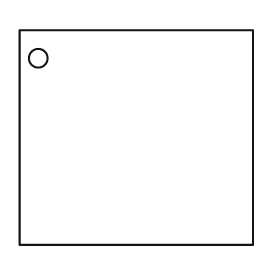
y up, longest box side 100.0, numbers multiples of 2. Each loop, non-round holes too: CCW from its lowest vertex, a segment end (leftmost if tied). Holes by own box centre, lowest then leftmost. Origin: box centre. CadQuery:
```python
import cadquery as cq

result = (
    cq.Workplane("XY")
    .moveTo(-50.0, -46.0)
    .lineTo(50.0, -46.0)
    .lineTo(50.0, 46.0)
    .lineTo(-50.0, 46.0)
    .close()
    .moveTo(-42.0, 34.0)
    .circle(4.0)
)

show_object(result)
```